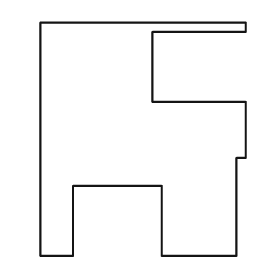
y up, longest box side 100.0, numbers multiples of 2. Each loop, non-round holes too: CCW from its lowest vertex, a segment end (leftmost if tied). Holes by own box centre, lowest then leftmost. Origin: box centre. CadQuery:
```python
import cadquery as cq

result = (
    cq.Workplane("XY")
    .moveTo(-44.0, -50.0)
    .lineTo(-30.0, -50.0)
    .lineTo(-30.0, -20.0)
    .lineTo(8.0, -20.0)
    .lineTo(8.0, -50.0)
    .lineTo(40.0, -50.0)
    .lineTo(40.0, -8.0)
    .lineTo(44.0, -8.0)
    .lineTo(44.0, 16.0)
    .lineTo(4.0, 16.0)
    .lineTo(4.0, 46.0)
    .lineTo(44.0, 46.0)
    .lineTo(44.0, 50.0)
    .lineTo(-44.0, 50.0)
    .close()
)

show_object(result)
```